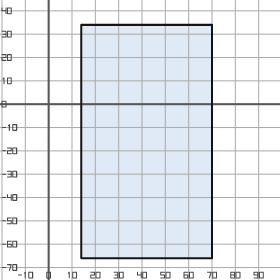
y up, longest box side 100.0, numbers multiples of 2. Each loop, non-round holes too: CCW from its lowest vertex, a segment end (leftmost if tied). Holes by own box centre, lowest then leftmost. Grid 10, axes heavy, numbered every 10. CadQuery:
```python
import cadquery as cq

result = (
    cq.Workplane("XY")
    .moveTo(14.0, -66.0)
    .lineTo(70.0, -66.0)
    .lineTo(70.0, 34.0)
    .lineTo(14.0, 34.0)
    .close()
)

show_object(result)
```